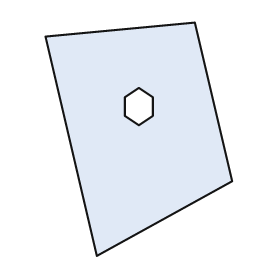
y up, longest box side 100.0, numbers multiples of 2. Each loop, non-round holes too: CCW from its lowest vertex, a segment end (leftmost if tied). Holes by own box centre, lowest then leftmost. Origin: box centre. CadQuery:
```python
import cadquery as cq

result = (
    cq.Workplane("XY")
    .moveTo(-18.0, -50.0)
    .lineTo(40.0, -18.0)
    .lineTo(24.0, 50.0)
    .lineTo(-40.0, 44.0)
    .close()
    .moveTo(0.0, 6.0)
    .lineTo(6.0, 10.0)
    .lineTo(6.0, 18.0)
    .lineTo(0.0, 22.0)
    .lineTo(-6.0, 18.0)
    .lineTo(-6.0, 10.0)
    .close()
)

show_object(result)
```